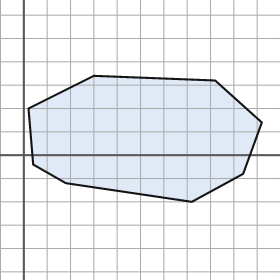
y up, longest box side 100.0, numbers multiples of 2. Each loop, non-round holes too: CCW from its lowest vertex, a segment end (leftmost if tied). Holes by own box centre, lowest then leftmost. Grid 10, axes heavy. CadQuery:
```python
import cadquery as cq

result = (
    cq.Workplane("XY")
    .moveTo(72.0, -20.0)
    .lineTo(94.0, -8.0)
    .lineTo(102.0, 14.0)
    .lineTo(82.0, 32.0)
    .lineTo(30.0, 34.0)
    .lineTo(2.0, 20.0)
    .lineTo(4.0, -4.0)
    .lineTo(18.0, -12.0)
    .close()
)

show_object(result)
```